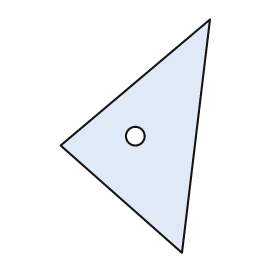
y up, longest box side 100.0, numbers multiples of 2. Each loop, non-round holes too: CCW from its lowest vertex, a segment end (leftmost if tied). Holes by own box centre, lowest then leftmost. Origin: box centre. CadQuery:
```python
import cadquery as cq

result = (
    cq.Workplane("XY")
    .moveTo(20.0, -50.0)
    .lineTo(32.0, 50.0)
    .lineTo(-32.0, -4.0)
    .close()
    .moveTo(0.0, 0.0)
    .circle(4.0)
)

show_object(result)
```